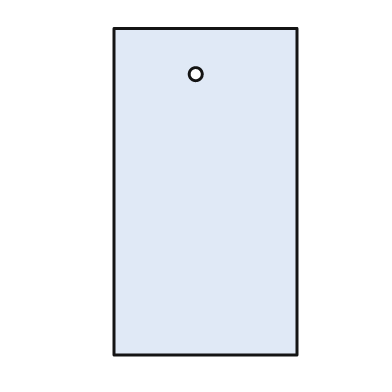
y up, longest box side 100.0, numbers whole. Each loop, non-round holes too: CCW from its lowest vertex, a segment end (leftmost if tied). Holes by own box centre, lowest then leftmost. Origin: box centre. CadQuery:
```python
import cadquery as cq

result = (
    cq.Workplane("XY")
    .moveTo(-28.0, -50.0)
    .lineTo(28.0, -50.0)
    .lineTo(28.0, 50.0)
    .lineTo(-28.0, 50.0)
    .close()
    .moveTo(-3.0, 36.0)
    .circle(2.0)
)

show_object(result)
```